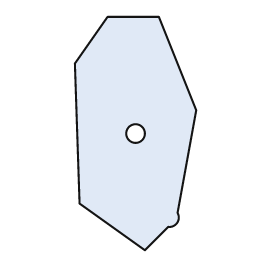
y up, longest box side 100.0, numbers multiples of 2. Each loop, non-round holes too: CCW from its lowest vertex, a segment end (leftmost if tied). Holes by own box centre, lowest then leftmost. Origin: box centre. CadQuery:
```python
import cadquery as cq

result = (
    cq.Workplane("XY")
    .moveTo(4.0, -50.0)
    .lineTo(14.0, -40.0)
    .threePointArc((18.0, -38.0), (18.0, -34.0))
    .lineTo(26.0, 10.0)
    .lineTo(10.0, 50.0)
    .lineTo(-12.0, 50.0)
    .lineTo(-26.0, 30.0)
    .lineTo(-24.0, -30.0)
    .close()
    .moveTo(0.0, 0.0)
    .circle(4.0)
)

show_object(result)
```